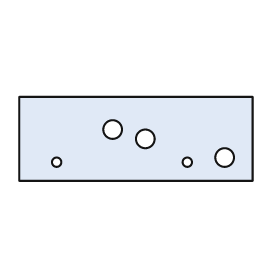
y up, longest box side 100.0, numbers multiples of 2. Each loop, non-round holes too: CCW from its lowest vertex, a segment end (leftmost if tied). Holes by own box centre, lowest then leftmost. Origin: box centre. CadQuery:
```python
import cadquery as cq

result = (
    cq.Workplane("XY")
    .moveTo(-50.0, -18.0)
    .lineTo(50.0, -18.0)
    .lineTo(50.0, 18.0)
    .lineTo(-50.0, 18.0)
    .close()
    .moveTo(-34.0, -10.0)
    .circle(2.0)
    .moveTo(22.0, -10.0)
    .circle(2.0)
    .moveTo(38.0, -8.0)
    .circle(4.0)
    .moveTo(4.0, 0.0)
    .circle(4.0)
    .moveTo(-10.0, 4.0)
    .circle(4.0)
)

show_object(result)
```